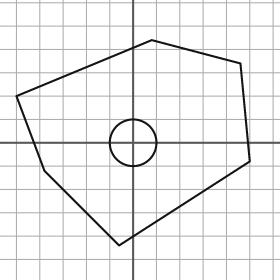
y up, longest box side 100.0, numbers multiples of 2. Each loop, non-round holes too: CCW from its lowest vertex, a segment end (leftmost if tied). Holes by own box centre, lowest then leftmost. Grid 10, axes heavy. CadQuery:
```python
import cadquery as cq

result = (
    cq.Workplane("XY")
    .moveTo(-6.0, -44.0)
    .lineTo(50.0, -8.0)
    .lineTo(46.0, 34.0)
    .lineTo(8.0, 44.0)
    .lineTo(-50.0, 20.0)
    .lineTo(-38.0, -12.0)
    .close()
    .moveTo(0.0, 0.0)
    .circle(10.0)
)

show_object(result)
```